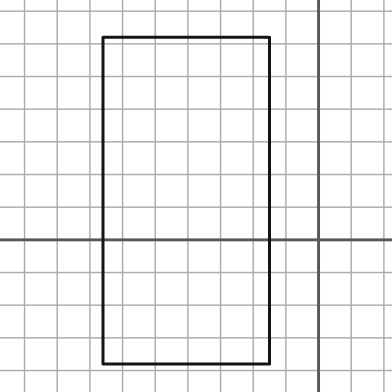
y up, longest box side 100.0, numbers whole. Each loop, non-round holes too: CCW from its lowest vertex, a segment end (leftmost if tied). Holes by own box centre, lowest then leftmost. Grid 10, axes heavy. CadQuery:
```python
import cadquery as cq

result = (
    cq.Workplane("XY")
    .moveTo(-66.0, -38.0)
    .lineTo(-15.0, -38.0)
    .lineTo(-15.0, 62.0)
    .lineTo(-66.0, 62.0)
    .close()
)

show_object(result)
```